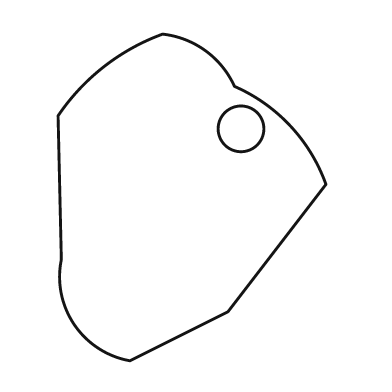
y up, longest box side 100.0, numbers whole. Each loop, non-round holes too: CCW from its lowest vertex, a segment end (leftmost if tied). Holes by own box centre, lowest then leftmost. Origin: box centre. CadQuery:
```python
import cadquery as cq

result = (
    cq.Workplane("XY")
    .moveTo(-19.0, -50.0)
    .lineTo(11.0, -35.0)
    .lineTo(41.0, 4.0)
    .threePointArc((30.0, 22.0), (13.0, 34.0))
    .threePointArc((4.0, 45.0), (-9.0, 50.0))
    .threePointArc((-27.0, 40.0), (-41.0, 25.0))
    .lineTo(-40.0, -19.0)
    .threePointArc((-36.0, -39.0), (-19.0, -50.0))
    .close()
    .moveTo(15.0, 21.0)
    .circle(7.0)
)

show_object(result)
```